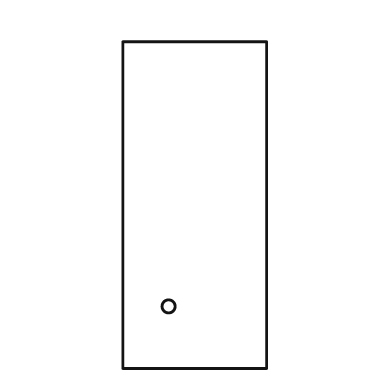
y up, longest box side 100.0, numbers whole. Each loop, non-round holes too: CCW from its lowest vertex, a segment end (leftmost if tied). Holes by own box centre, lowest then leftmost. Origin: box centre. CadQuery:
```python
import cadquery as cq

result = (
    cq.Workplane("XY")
    .moveTo(-22.0, -50.0)
    .lineTo(22.0, -50.0)
    .lineTo(22.0, 50.0)
    .lineTo(-22.0, 50.0)
    .close()
    .moveTo(-8.0, -31.0)
    .circle(2.0)
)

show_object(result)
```